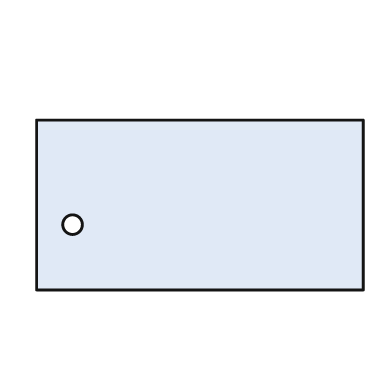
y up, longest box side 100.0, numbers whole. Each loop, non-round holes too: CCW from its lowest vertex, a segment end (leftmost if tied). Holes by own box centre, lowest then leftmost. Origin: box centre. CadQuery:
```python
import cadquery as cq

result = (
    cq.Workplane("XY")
    .moveTo(-50.0, -26.0)
    .lineTo(50.0, -26.0)
    .lineTo(50.0, 26.0)
    .lineTo(-50.0, 26.0)
    .close()
    .moveTo(-39.0, -6.0)
    .circle(3.0)
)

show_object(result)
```